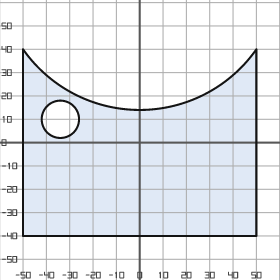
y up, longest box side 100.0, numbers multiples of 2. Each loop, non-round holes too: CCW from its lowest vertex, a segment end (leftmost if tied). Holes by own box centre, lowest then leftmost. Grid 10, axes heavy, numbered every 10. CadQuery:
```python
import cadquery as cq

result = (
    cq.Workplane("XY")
    .moveTo(-50.0, -40.0)
    .lineTo(50.0, -40.0)
    .lineTo(50.0, 40.0)
    .threePointArc((0.0, 14.0), (-50.0, 40.0))
    .close()
    .moveTo(-34.0, 10.0)
    .circle(8.0)
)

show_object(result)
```